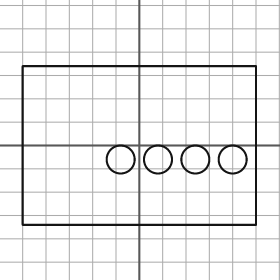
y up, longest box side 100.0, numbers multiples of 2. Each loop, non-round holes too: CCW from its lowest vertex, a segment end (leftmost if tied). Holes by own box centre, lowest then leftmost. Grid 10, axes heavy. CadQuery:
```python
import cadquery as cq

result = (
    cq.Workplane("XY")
    .moveTo(-50.0, -34.0)
    .lineTo(50.0, -34.0)
    .lineTo(50.0, 34.0)
    .lineTo(-50.0, 34.0)
    .close()
    .moveTo(-8.0, -6.0)
    .circle(6.0)
    .moveTo(8.0, -6.0)
    .circle(6.0)
    .moveTo(24.0, -6.0)
    .circle(6.0)
    .moveTo(40.0, -6.0)
    .circle(6.0)
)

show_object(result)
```